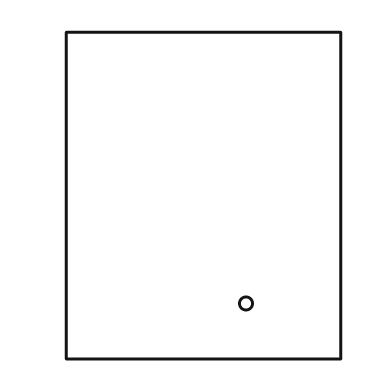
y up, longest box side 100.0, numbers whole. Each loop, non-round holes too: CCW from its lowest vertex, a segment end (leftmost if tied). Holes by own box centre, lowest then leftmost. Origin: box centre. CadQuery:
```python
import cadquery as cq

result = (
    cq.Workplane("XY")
    .moveTo(-42.0, -50.0)
    .lineTo(42.0, -50.0)
    .lineTo(42.0, 50.0)
    .lineTo(-42.0, 50.0)
    .close()
    .moveTo(13.0, -33.0)
    .circle(2.0)
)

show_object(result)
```